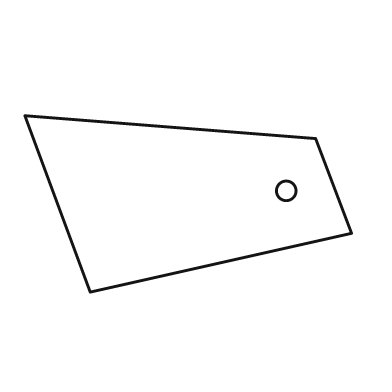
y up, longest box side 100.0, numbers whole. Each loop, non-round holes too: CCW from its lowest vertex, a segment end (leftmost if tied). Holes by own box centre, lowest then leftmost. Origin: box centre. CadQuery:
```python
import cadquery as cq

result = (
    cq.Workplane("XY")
    .moveTo(-30.0, -27.0)
    .lineTo(50.0, -9.0)
    .lineTo(39.0, 20.0)
    .lineTo(-50.0, 27.0)
    .close()
    .moveTo(30.0, 4.0)
    .circle(3.0)
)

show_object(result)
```